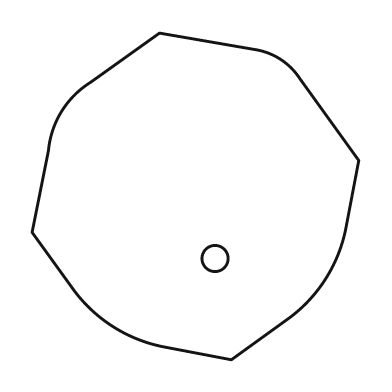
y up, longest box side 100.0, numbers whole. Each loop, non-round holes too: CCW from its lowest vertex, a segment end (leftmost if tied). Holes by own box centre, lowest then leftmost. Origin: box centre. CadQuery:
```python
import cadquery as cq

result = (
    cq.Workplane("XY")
    .moveTo(11.0, -50.0)
    .lineTo(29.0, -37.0)
    .threePointArc((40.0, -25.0), (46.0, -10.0))
    .lineTo(50.0, 11.0)
    .lineTo(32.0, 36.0)
    .threePointArc((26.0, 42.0), (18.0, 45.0))
    .lineTo(-11.0, 50.0)
    .lineTo(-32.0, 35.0)
    .threePointArc((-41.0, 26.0), (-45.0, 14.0))
    .lineTo(-50.0, -11.0)
    .lineTo(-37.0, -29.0)
    .threePointArc((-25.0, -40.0), (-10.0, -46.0))
    .close()
    .moveTo(6.0, -19.0)
    .circle(4.0)
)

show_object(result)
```